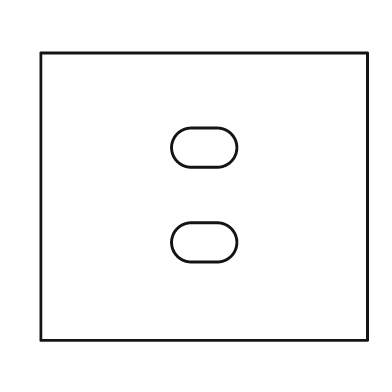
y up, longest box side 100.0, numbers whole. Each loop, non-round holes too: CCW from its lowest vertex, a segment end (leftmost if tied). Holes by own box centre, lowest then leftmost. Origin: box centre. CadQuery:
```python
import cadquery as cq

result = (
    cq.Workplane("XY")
    .moveTo(-50.0, -44.0)
    .lineTo(50.0, -44.0)
    .lineTo(50.0, 44.0)
    .lineTo(-50.0, 44.0)
    .close()
    .moveTo(-4.0, -20.0)
    .lineTo(4.0, -20.0)
    .threePointArc((10.0, -14.0), (4.0, -8.0))
    .lineTo(-4.0, -8.0)
    .threePointArc((-10.0, -14.0), (-4.0, -20.0))
    .close()
    .moveTo(-4.0, 9.0)
    .lineTo(4.0, 9.0)
    .threePointArc((10.0, 15.0), (4.0, 21.0))
    .lineTo(-4.0, 21.0)
    .threePointArc((-10.0, 15.0), (-4.0, 9.0))
    .close()
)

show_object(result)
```